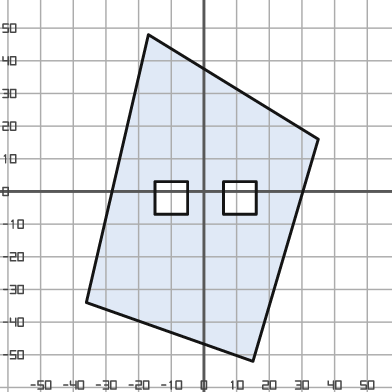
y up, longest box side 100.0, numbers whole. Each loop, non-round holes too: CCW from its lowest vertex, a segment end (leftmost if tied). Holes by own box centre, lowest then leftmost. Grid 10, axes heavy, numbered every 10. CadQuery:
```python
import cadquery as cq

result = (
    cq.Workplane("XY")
    .moveTo(15.0, -52.0)
    .lineTo(35.0, 16.0)
    .lineTo(-17.0, 48.0)
    .lineTo(-36.0, -34.0)
    .close()
    .moveTo(-15.0, -7.0)
    .lineTo(-5.0, -7.0)
    .lineTo(-5.0, 3.0)
    .lineTo(-15.0, 3.0)
    .close()
    .moveTo(6.0, -7.0)
    .lineTo(16.0, -7.0)
    .lineTo(16.0, 3.0)
    .lineTo(6.0, 3.0)
    .close()
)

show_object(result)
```